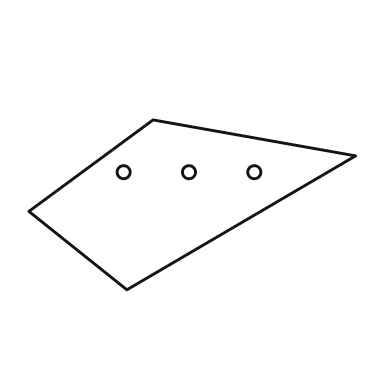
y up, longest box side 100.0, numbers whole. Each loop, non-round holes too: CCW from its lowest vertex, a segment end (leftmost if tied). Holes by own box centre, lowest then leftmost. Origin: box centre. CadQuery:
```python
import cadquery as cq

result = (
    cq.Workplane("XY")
    .moveTo(-20.0, -26.0)
    .lineTo(50.0, 15.0)
    .lineTo(-12.0, 26.0)
    .lineTo(-50.0, -2.0)
    .close()
    .moveTo(-21.0, 10.0)
    .circle(2.0)
    .moveTo(-1.0, 10.0)
    .circle(2.0)
    .moveTo(19.0, 10.0)
    .circle(2.0)
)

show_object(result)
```